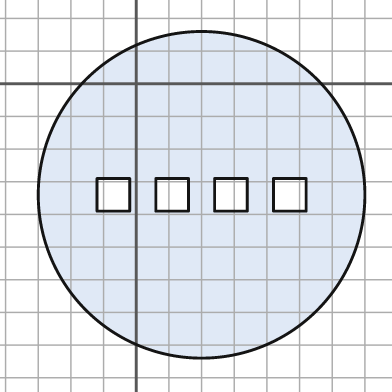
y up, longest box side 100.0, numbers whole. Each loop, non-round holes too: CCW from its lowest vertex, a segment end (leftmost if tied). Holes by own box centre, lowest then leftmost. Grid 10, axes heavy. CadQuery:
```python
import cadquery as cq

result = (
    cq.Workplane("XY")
    .moveTo(20.0, -34.0)
    .circle(50.0)
    .moveTo(-12.0, -39.0)
    .lineTo(-2.0, -39.0)
    .lineTo(-2.0, -29.0)
    .lineTo(-12.0, -29.0)
    .close()
    .moveTo(6.0, -39.0)
    .lineTo(16.0, -39.0)
    .lineTo(16.0, -29.0)
    .lineTo(6.0, -29.0)
    .close()
    .moveTo(24.0, -39.0)
    .lineTo(34.0, -39.0)
    .lineTo(34.0, -29.0)
    .lineTo(24.0, -29.0)
    .close()
    .moveTo(42.0, -39.0)
    .lineTo(52.0, -39.0)
    .lineTo(52.0, -29.0)
    .lineTo(42.0, -29.0)
    .close()
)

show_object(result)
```